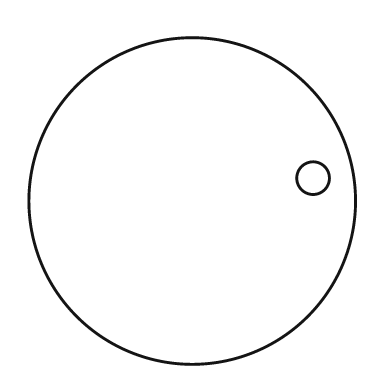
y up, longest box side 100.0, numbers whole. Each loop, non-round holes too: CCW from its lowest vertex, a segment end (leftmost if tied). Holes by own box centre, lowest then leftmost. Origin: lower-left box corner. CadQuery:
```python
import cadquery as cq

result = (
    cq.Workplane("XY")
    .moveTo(50.0, 50.0)
    .circle(50.0)
    .moveTo(87.0, 57.0)
    .circle(5.0)
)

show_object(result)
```